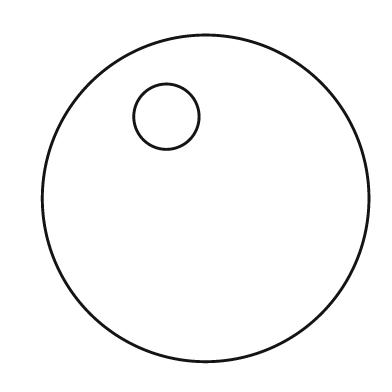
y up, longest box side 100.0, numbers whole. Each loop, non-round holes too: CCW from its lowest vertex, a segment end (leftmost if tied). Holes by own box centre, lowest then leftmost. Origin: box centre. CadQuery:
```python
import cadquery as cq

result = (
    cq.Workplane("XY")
    .moveTo(0.0, 0.0)
    .circle(50.0)
    .moveTo(-12.0, 25.0)
    .circle(10.0)
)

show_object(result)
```